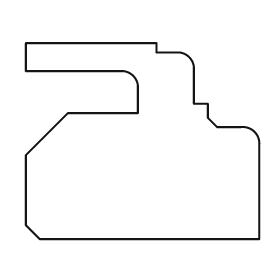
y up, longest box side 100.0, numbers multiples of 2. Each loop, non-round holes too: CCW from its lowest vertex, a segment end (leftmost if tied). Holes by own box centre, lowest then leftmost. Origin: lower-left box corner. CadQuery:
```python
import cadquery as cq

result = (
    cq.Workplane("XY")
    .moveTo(6.0, 0.0)
    .lineTo(100.0, 0.0)
    .lineTo(100.0, 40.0)
    .threePointArc((98.0, 46.0), (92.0, 48.0))
    .lineTo(82.0, 48.0)
    .lineTo(78.0, 52.0)
    .lineTo(78.0, 58.0)
    .lineTo(72.0, 58.0)
    .lineTo(72.0, 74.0)
    .threePointArc((70.0, 78.0), (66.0, 80.0))
    .lineTo(56.0, 80.0)
    .lineTo(56.0, 84.0)
    .lineTo(0.0, 84.0)
    .lineTo(0.0, 72.0)
    .lineTo(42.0, 72.0)
    .threePointArc((46.0, 70.0), (48.0, 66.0))
    .lineTo(48.0, 54.0)
    .lineTo(18.0, 54.0)
    .lineTo(0.0, 36.0)
    .lineTo(0.0, 6.0)
    .close()
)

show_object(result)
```